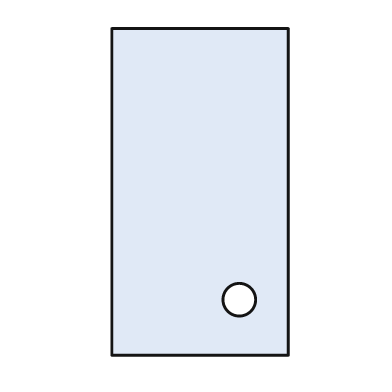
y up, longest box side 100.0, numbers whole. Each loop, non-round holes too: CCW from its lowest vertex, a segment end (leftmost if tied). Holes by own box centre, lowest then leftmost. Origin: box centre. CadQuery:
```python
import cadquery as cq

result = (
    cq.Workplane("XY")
    .moveTo(-27.0, -50.0)
    .lineTo(27.0, -50.0)
    .lineTo(27.0, 50.0)
    .lineTo(-27.0, 50.0)
    .close()
    .moveTo(12.0, -33.0)
    .circle(5.0)
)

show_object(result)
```